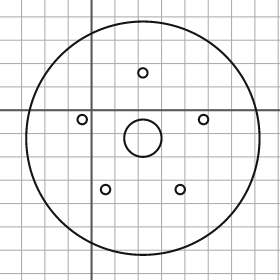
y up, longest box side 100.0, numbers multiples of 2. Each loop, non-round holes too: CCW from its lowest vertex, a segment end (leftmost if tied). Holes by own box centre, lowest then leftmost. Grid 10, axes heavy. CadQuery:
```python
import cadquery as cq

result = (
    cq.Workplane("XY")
    .moveTo(22.0, -12.0)
    .circle(50.0)
    .moveTo(6.0, -34.0)
    .circle(2.0)
    .moveTo(38.0, -34.0)
    .circle(2.0)
    .moveTo(22.0, -12.0)
    .circle(8.0)
    .moveTo(-4.0, -4.0)
    .circle(2.0)
    .moveTo(48.0, -4.0)
    .circle(2.0)
    .moveTo(22.0, 16.0)
    .circle(2.0)
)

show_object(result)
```